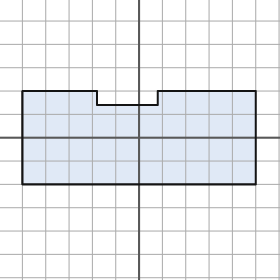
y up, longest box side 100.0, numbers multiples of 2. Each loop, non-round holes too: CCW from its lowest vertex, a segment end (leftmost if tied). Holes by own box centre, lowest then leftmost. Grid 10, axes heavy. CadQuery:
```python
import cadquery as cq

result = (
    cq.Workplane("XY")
    .moveTo(-50.0, -20.0)
    .lineTo(50.0, -20.0)
    .lineTo(50.0, 20.0)
    .lineTo(8.0, 20.0)
    .lineTo(8.0, 14.0)
    .lineTo(-18.0, 14.0)
    .lineTo(-18.0, 20.0)
    .lineTo(-50.0, 20.0)
    .close()
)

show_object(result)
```